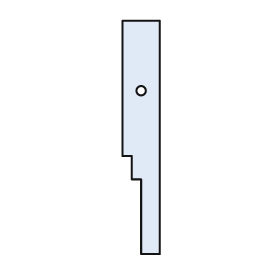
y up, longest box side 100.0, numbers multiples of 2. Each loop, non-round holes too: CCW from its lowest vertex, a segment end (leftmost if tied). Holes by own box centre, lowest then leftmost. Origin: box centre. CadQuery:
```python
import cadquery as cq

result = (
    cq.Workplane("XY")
    .moveTo(0.0, -50.0)
    .lineTo(8.0, -50.0)
    .lineTo(8.0, 50.0)
    .lineTo(-8.0, 50.0)
    .lineTo(-8.0, -8.0)
    .lineTo(-4.0, -8.0)
    .lineTo(-4.0, -18.0)
    .lineTo(0.0, -18.0)
    .close()
    .moveTo(0.0, 20.0)
    .circle(2.0)
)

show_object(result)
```